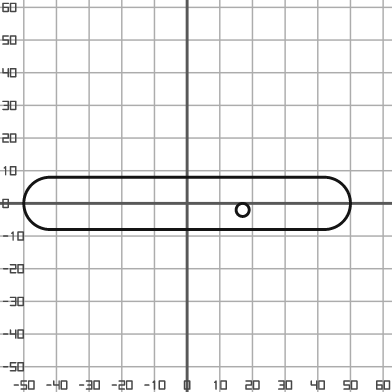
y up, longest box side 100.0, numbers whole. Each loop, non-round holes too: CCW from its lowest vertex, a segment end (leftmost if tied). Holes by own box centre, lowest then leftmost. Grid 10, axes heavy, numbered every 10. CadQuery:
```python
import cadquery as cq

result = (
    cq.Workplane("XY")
    .moveTo(-42.0, -8.0)
    .lineTo(42.0, -8.0)
    .threePointArc((50.0, 0.0), (42.0, 8.0))
    .lineTo(-42.0, 8.0)
    .threePointArc((-50.0, 0.0), (-42.0, -8.0))
    .close()
    .moveTo(17.0, -2.0)
    .circle(2.0)
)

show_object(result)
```